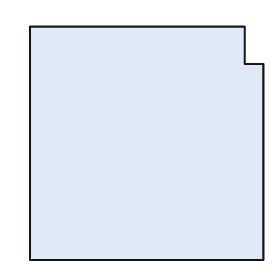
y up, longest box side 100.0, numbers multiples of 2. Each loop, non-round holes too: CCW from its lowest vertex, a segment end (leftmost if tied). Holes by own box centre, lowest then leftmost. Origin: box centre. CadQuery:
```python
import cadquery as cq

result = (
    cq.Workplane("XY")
    .moveTo(-50.0, -50.0)
    .lineTo(50.0, -50.0)
    .lineTo(50.0, 34.0)
    .lineTo(42.0, 34.0)
    .lineTo(42.0, 50.0)
    .lineTo(-50.0, 50.0)
    .close()
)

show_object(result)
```